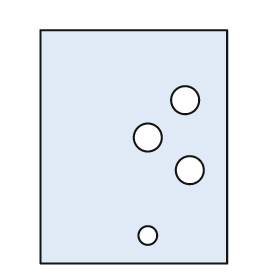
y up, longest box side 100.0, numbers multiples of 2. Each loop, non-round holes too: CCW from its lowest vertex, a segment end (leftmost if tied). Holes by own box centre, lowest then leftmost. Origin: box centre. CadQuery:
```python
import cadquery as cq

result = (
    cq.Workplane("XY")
    .moveTo(-40.0, -50.0)
    .lineTo(40.0, -50.0)
    .lineTo(40.0, 50.0)
    .lineTo(-40.0, 50.0)
    .close()
    .moveTo(6.0, -38.0)
    .circle(4.0)
    .moveTo(24.0, -10.0)
    .circle(6.0)
    .moveTo(6.0, 4.0)
    .circle(6.0)
    .moveTo(22.0, 20.0)
    .circle(6.0)
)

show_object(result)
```